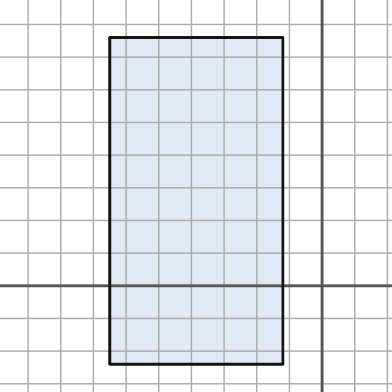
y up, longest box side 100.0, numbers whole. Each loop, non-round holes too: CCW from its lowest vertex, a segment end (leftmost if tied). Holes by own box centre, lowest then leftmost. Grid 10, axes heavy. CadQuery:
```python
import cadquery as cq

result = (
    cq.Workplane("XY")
    .moveTo(-65.0, -24.0)
    .lineTo(-12.0, -24.0)
    .lineTo(-12.0, 76.0)
    .lineTo(-65.0, 76.0)
    .close()
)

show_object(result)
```